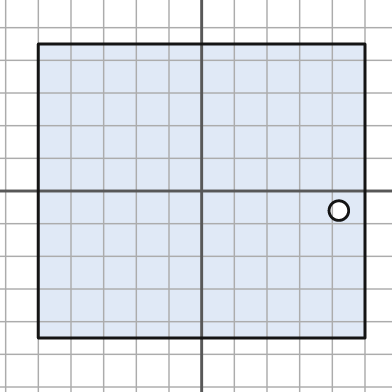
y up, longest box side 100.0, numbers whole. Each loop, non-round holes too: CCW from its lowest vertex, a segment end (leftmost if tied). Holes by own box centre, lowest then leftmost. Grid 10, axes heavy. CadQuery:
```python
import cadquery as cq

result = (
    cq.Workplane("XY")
    .moveTo(-50.0, -45.0)
    .lineTo(50.0, -45.0)
    .lineTo(50.0, 45.0)
    .lineTo(-50.0, 45.0)
    .close()
    .moveTo(42.0, -6.0)
    .circle(3.0)
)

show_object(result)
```